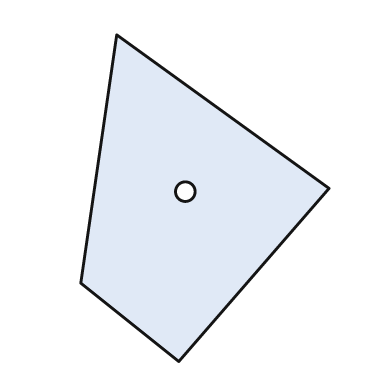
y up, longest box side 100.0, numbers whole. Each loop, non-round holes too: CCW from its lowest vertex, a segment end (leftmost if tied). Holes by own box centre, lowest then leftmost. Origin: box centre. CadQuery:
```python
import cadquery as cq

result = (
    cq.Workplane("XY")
    .moveTo(-8.0, -50.0)
    .lineTo(38.0, 3.0)
    .lineTo(-27.0, 50.0)
    .lineTo(-38.0, -26.0)
    .close()
    .moveTo(-6.0, 2.0)
    .circle(3.0)
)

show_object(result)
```